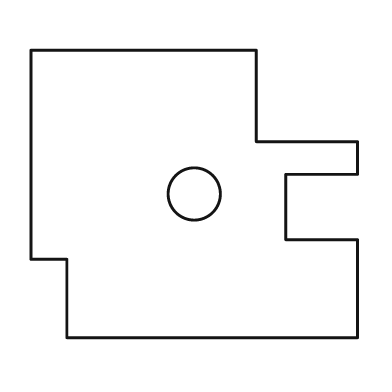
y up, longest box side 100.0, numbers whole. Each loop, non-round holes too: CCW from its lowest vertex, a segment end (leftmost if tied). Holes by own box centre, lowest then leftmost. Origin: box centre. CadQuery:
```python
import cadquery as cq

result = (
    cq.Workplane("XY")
    .moveTo(-39.0, -44.0)
    .lineTo(50.0, -44.0)
    .lineTo(50.0, -14.0)
    .lineTo(28.0, -14.0)
    .lineTo(28.0, 6.0)
    .lineTo(50.0, 6.0)
    .lineTo(50.0, 16.0)
    .lineTo(19.0, 16.0)
    .lineTo(19.0, 44.0)
    .lineTo(-50.0, 44.0)
    .lineTo(-50.0, -20.0)
    .lineTo(-39.0, -20.0)
    .close()
    .moveTo(0.0, 0.0)
    .circle(8.0)
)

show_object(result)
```